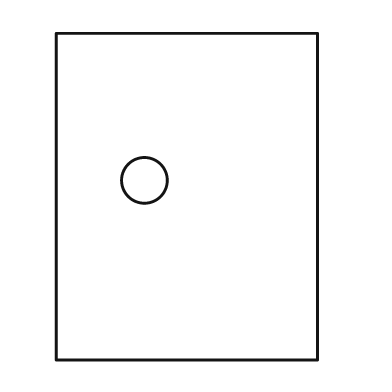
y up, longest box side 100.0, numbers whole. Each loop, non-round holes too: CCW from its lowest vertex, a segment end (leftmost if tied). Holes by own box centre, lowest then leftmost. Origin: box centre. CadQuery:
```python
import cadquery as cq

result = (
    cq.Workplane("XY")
    .moveTo(-40.0, -50.0)
    .lineTo(40.0, -50.0)
    .lineTo(40.0, 50.0)
    .lineTo(-40.0, 50.0)
    .close()
    .moveTo(-13.0, 5.0)
    .circle(7.0)
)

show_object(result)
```